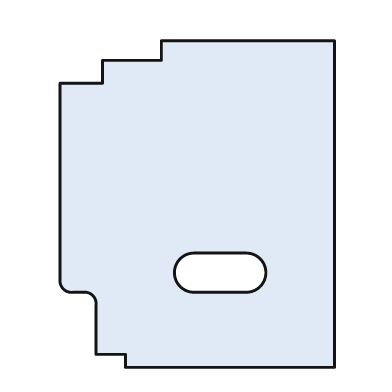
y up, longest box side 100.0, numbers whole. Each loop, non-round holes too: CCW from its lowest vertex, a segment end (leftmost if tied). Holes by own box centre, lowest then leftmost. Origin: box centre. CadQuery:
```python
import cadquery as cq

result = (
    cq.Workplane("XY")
    .moveTo(-22.0, -50.0)
    .lineTo(42.0, -50.0)
    .lineTo(42.0, 50.0)
    .lineTo(-11.0, 50.0)
    .lineTo(-11.0, 44.0)
    .lineTo(-29.0, 44.0)
    .lineTo(-29.0, 37.0)
    .lineTo(-42.0, 37.0)
    .lineTo(-42.0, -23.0)
    .threePointArc((-41.0, -26.0), (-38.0, -27.0))
    .lineTo(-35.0, -27.0)
    .threePointArc((-32.0, -28.0), (-31.0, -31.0))
    .lineTo(-31.0, -46.0)
    .lineTo(-22.0, -46.0)
    .close()
    .moveTo(-1.0, -27.0)
    .lineTo(15.0, -27.0)
    .threePointArc((21.0, -21.0), (15.0, -15.0))
    .lineTo(-1.0, -15.0)
    .threePointArc((-7.0, -21.0), (-1.0, -27.0))
    .close()
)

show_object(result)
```